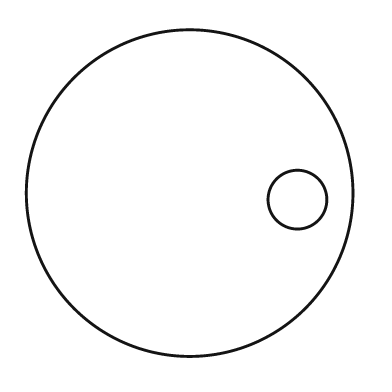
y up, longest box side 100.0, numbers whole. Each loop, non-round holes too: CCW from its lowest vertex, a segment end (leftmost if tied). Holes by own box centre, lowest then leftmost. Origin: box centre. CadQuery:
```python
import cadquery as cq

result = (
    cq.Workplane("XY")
    .moveTo(0.0, 0.0)
    .circle(50.0)
    .moveTo(33.0, -2.0)
    .circle(9.0)
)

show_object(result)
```